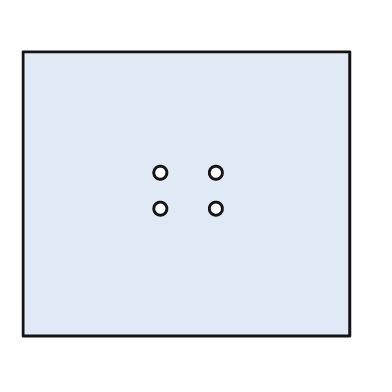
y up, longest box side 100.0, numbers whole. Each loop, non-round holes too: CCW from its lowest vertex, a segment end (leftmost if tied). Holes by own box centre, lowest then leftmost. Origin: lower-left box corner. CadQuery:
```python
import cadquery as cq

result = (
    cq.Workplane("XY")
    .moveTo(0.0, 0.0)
    .lineTo(100.0, 0.0)
    .lineTo(100.0, 87.0)
    .lineTo(0.0, 87.0)
    .close()
    .moveTo(42.0, 39.0)
    .circle(2.0)
    .moveTo(59.0, 39.0)
    .circle(2.0)
    .moveTo(42.0, 50.0)
    .circle(2.0)
    .moveTo(59.0, 50.0)
    .circle(2.0)
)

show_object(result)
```